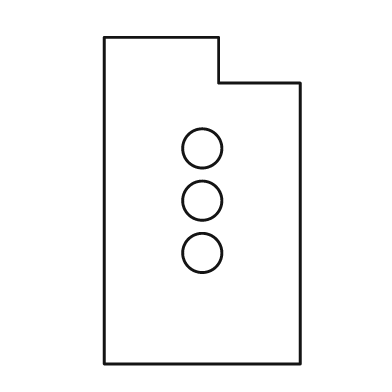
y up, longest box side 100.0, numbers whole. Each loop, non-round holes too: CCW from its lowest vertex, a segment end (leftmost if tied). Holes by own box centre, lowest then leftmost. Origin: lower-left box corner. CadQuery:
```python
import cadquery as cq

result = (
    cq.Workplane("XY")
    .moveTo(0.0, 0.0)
    .lineTo(60.0, 0.0)
    .lineTo(60.0, 86.0)
    .lineTo(35.0, 86.0)
    .lineTo(35.0, 100.0)
    .lineTo(0.0, 100.0)
    .close()
    .moveTo(30.0, 34.0)
    .circle(6.0)
    .moveTo(30.0, 50.0)
    .circle(6.0)
    .moveTo(30.0, 66.0)
    .circle(6.0)
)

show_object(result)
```